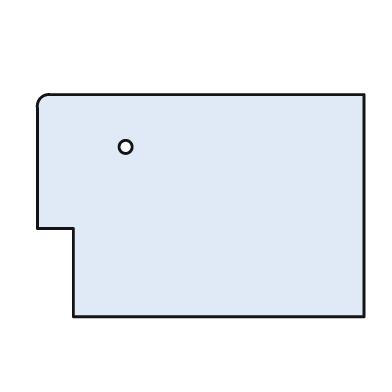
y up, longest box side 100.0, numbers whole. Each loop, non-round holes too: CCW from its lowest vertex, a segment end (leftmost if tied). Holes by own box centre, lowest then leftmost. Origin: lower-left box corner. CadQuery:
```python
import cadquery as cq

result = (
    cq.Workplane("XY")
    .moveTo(11.0, 0.0)
    .lineTo(100.0, 0.0)
    .lineTo(100.0, 68.0)
    .lineTo(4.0, 68.0)
    .threePointArc((1.0, 67.0), (0.0, 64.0))
    .lineTo(0.0, 27.0)
    .lineTo(11.0, 27.0)
    .close()
    .moveTo(27.0, 52.0)
    .circle(2.0)
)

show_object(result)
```